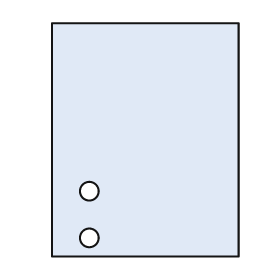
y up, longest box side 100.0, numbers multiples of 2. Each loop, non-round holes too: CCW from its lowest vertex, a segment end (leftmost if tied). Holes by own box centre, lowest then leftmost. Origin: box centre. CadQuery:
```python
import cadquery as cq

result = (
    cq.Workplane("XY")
    .moveTo(-40.0, -50.0)
    .lineTo(40.0, -50.0)
    .lineTo(40.0, 50.0)
    .lineTo(-40.0, 50.0)
    .close()
    .moveTo(-24.0, -42.0)
    .circle(4.0)
    .moveTo(-24.0, -22.0)
    .circle(4.0)
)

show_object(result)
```